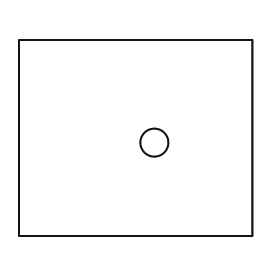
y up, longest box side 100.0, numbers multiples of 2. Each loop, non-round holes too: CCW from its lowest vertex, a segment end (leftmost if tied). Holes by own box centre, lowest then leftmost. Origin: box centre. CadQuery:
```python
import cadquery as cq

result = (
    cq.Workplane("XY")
    .moveTo(-50.0, -42.0)
    .lineTo(50.0, -42.0)
    .lineTo(50.0, 42.0)
    .lineTo(-50.0, 42.0)
    .close()
    .moveTo(8.0, -2.0)
    .circle(6.0)
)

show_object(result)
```